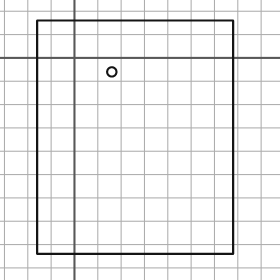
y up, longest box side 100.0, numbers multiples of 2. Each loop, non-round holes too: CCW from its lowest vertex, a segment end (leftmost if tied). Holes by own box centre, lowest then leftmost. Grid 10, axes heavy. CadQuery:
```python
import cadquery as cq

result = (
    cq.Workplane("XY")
    .moveTo(-16.0, -84.0)
    .lineTo(68.0, -84.0)
    .lineTo(68.0, 16.0)
    .lineTo(-16.0, 16.0)
    .close()
    .moveTo(16.0, -6.0)
    .circle(2.0)
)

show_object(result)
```